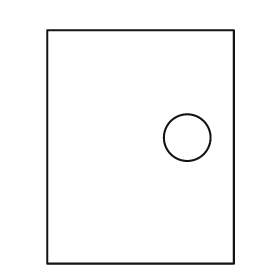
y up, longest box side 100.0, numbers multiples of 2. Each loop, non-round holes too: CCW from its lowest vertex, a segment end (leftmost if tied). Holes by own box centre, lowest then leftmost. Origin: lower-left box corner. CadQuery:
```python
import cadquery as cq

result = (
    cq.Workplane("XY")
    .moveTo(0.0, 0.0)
    .lineTo(80.0, 0.0)
    .lineTo(80.0, 100.0)
    .lineTo(0.0, 100.0)
    .close()
    .moveTo(60.0, 54.0)
    .circle(10.0)
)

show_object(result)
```